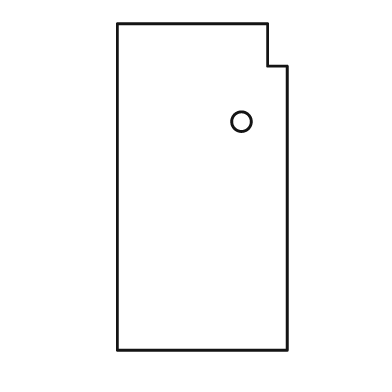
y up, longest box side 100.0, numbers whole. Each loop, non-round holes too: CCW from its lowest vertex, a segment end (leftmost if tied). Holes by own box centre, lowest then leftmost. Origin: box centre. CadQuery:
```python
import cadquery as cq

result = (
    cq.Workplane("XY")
    .moveTo(-26.0, -50.0)
    .lineTo(26.0, -50.0)
    .lineTo(26.0, 37.0)
    .lineTo(20.0, 37.0)
    .lineTo(20.0, 50.0)
    .lineTo(-26.0, 50.0)
    .close()
    .moveTo(12.0, 20.0)
    .circle(3.0)
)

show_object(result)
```